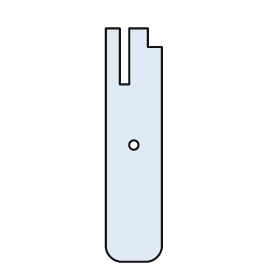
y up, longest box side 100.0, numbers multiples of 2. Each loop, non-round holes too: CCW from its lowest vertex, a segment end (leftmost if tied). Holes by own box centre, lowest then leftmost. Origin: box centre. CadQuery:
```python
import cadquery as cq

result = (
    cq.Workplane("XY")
    .moveTo(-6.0, -50.0)
    .lineTo(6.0, -50.0)
    .threePointArc((10.0, -48.0), (12.0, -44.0))
    .lineTo(12.0, 42.0)
    .lineTo(6.0, 42.0)
    .lineTo(6.0, 50.0)
    .lineTo(-2.0, 50.0)
    .lineTo(-2.0, 26.0)
    .lineTo(-6.0, 26.0)
    .lineTo(-6.0, 50.0)
    .lineTo(-12.0, 50.0)
    .lineTo(-12.0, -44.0)
    .threePointArc((-10.0, -48.0), (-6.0, -50.0))
    .close()
    .moveTo(0.0, 0.0)
    .circle(2.0)
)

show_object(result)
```